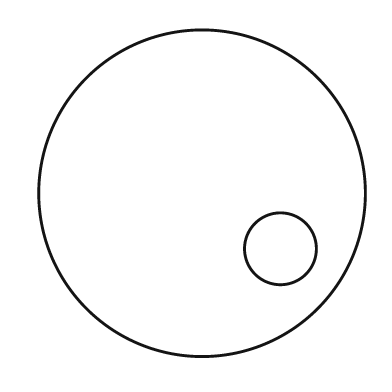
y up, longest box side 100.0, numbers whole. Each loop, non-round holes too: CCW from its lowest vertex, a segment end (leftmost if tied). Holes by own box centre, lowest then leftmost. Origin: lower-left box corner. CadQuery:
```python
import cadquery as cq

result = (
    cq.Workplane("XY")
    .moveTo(50.0, 50.0)
    .circle(50.0)
    .moveTo(74.0, 33.0)
    .circle(11.0)
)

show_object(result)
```